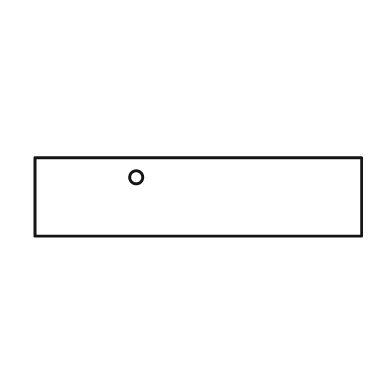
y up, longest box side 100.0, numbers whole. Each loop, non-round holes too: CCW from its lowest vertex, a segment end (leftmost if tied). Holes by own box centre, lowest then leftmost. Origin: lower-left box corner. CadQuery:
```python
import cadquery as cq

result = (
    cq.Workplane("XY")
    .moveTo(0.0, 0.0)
    .lineTo(100.0, 0.0)
    .lineTo(100.0, 24.0)
    .lineTo(0.0, 24.0)
    .close()
    .moveTo(31.0, 18.0)
    .circle(2.0)
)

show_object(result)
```